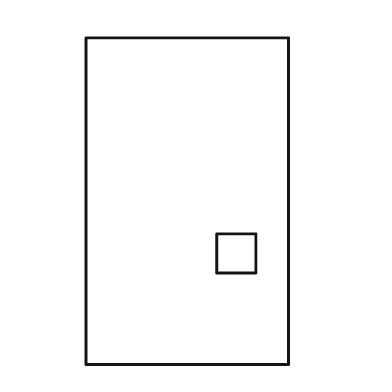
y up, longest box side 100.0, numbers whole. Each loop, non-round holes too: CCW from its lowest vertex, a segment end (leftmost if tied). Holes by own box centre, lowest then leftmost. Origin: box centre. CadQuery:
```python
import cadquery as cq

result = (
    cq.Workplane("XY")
    .moveTo(-31.0, -50.0)
    .lineTo(31.0, -50.0)
    .lineTo(31.0, 50.0)
    .lineTo(-31.0, 50.0)
    .close()
    .moveTo(9.0, -22.0)
    .lineTo(21.0, -22.0)
    .lineTo(21.0, -10.0)
    .lineTo(9.0, -10.0)
    .close()
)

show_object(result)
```